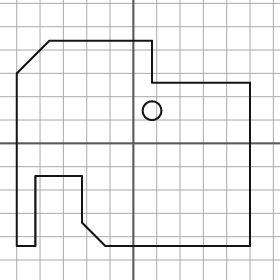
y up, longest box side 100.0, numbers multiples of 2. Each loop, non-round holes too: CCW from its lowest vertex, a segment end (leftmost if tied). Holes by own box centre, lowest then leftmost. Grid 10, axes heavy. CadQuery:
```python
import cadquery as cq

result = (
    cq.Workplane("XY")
    .moveTo(-50.0, -44.0)
    .lineTo(-42.0, -44.0)
    .lineTo(-42.0, -14.0)
    .lineTo(-22.0, -14.0)
    .lineTo(-22.0, -34.0)
    .lineTo(-12.0, -44.0)
    .lineTo(50.0, -44.0)
    .lineTo(50.0, 26.0)
    .lineTo(8.0, 26.0)
    .lineTo(8.0, 44.0)
    .lineTo(-36.0, 44.0)
    .lineTo(-50.0, 30.0)
    .close()
    .moveTo(8.0, 14.0)
    .circle(4.0)
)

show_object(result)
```